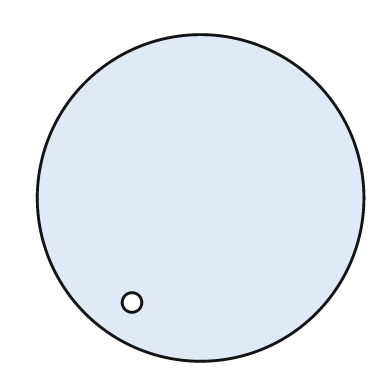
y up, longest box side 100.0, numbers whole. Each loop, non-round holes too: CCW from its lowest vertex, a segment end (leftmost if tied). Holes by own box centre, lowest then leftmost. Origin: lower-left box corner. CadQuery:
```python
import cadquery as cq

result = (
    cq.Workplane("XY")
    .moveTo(50.0, 50.0)
    .circle(50.0)
    .moveTo(29.0, 18.0)
    .circle(3.0)
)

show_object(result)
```